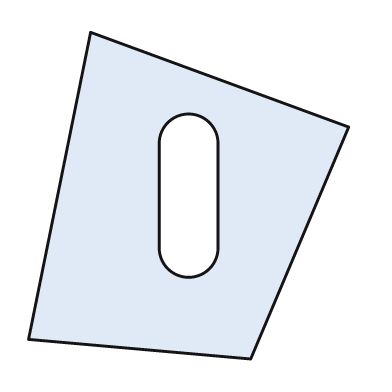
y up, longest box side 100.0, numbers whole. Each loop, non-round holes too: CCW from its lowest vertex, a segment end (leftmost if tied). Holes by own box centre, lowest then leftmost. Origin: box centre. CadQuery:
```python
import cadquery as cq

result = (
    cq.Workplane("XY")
    .moveTo(19.0, -50.0)
    .lineTo(49.0, 21.0)
    .lineTo(-30.0, 50.0)
    .lineTo(-49.0, -44.0)
    .close()
    .moveTo(-9.0, -16.0)
    .threePointArc((0.0, -25.0), (9.0, -16.0))
    .lineTo(9.0, 16.0)
    .threePointArc((0.0, 25.0), (-9.0, 16.0))
    .close()
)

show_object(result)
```